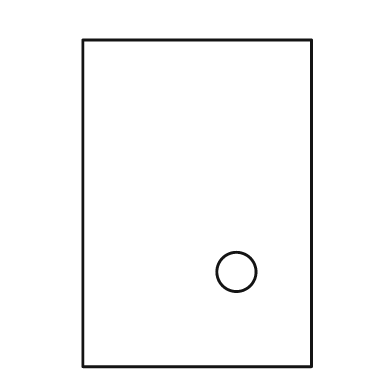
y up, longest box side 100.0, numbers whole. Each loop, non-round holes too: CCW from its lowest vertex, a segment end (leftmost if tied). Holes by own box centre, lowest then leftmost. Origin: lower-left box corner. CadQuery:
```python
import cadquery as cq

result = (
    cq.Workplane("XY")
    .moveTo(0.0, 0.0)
    .lineTo(70.0, 0.0)
    .lineTo(70.0, 100.0)
    .lineTo(0.0, 100.0)
    .close()
    .moveTo(47.0, 29.0)
    .circle(6.0)
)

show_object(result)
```